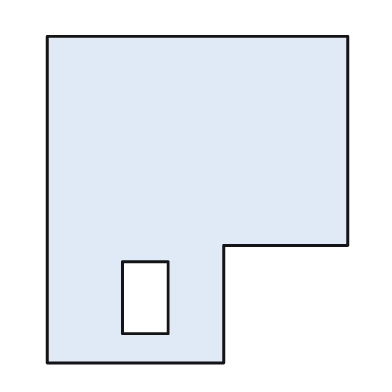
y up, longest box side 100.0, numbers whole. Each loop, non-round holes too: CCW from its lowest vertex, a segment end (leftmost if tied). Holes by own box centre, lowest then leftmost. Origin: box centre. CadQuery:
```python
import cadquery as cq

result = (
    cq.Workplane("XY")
    .moveTo(-46.0, -50.0)
    .lineTo(8.0, -50.0)
    .lineTo(8.0, -14.0)
    .lineTo(46.0, -14.0)
    .lineTo(46.0, 50.0)
    .lineTo(-46.0, 50.0)
    .close()
    .moveTo(-23.0, -41.0)
    .lineTo(-9.0, -41.0)
    .lineTo(-9.0, -19.0)
    .lineTo(-23.0, -19.0)
    .close()
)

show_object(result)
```